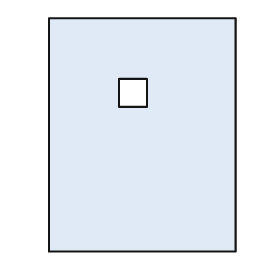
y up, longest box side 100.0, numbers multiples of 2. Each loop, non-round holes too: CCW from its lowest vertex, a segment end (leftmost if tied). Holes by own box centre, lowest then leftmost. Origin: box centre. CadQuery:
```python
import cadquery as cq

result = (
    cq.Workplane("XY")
    .moveTo(-40.0, -50.0)
    .lineTo(40.0, -50.0)
    .lineTo(40.0, 50.0)
    .lineTo(-40.0, 50.0)
    .close()
    .moveTo(-10.0, 12.0)
    .lineTo(2.0, 12.0)
    .lineTo(2.0, 24.0)
    .lineTo(-10.0, 24.0)
    .close()
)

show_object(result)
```